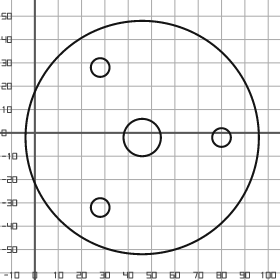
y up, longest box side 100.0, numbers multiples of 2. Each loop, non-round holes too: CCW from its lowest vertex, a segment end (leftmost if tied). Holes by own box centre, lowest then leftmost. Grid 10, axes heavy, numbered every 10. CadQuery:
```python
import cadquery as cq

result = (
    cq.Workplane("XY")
    .moveTo(46.0, -2.0)
    .circle(50.0)
    .moveTo(28.0, -32.0)
    .circle(4.0)
    .moveTo(46.0, -2.0)
    .circle(8.0)
    .moveTo(80.0, -2.0)
    .circle(4.0)
    .moveTo(28.0, 28.0)
    .circle(4.0)
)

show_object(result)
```